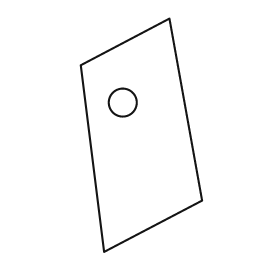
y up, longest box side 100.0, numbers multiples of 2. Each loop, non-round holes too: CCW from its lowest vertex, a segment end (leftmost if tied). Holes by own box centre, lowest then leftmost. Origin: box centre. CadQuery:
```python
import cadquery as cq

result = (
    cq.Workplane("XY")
    .moveTo(-16.0, -50.0)
    .lineTo(26.0, -28.0)
    .lineTo(12.0, 50.0)
    .lineTo(-26.0, 30.0)
    .close()
    .moveTo(-8.0, 14.0)
    .circle(6.0)
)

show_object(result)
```